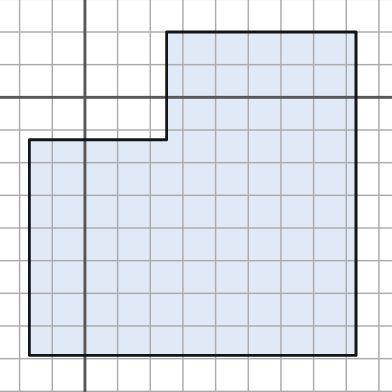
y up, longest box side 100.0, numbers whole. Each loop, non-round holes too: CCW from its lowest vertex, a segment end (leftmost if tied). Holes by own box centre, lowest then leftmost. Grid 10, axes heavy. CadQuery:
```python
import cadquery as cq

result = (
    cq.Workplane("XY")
    .moveTo(-17.0, -79.0)
    .lineTo(83.0, -79.0)
    .lineTo(83.0, 20.0)
    .lineTo(25.0, 20.0)
    .lineTo(25.0, -13.0)
    .lineTo(-17.0, -13.0)
    .close()
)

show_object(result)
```